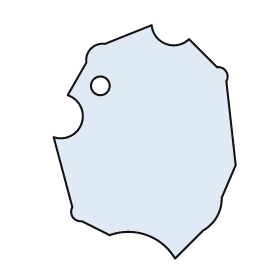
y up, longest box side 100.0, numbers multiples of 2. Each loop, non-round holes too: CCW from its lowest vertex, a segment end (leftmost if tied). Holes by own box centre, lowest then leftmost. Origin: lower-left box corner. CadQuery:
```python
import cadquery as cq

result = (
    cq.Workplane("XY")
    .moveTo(52.0, 0.0)
    .lineTo(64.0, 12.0)
    .threePointArc((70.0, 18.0), (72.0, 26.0))
    .lineTo(78.0, 40.0)
    .lineTo(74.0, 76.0)
    .threePointArc((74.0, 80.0), (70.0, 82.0))
    .lineTo(58.0, 94.0)
    .threePointArc((48.0, 92.0), (42.0, 100.0))
    .lineTo(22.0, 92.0)
    .threePointArc((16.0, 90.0), (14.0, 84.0))
    .lineTo(6.0, 70.0)
    .threePointArc((12.0, 58.0), (0.0, 52.0))
    .lineTo(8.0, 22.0)
    .threePointArc((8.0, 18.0), (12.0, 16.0))
    .lineTo(24.0, 10.0)
    .threePointArc((40.0, 10.0), (52.0, 0.0))
    .close()
    .moveTo(20.0, 74.0)
    .circle(4.0)
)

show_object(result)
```